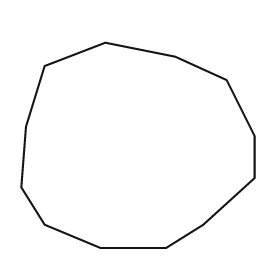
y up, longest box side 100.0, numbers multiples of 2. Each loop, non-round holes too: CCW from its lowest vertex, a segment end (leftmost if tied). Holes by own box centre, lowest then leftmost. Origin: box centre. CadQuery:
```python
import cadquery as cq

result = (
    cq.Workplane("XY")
    .moveTo(-16.0, -44.0)
    .lineTo(12.0, -44.0)
    .lineTo(28.0, -34.0)
    .lineTo(50.0, -14.0)
    .lineTo(50.0, 4.0)
    .lineTo(38.0, 28.0)
    .lineTo(16.0, 38.0)
    .lineTo(-14.0, 44.0)
    .lineTo(-40.0, 34.0)
    .lineTo(-48.0, 8.0)
    .lineTo(-50.0, -18.0)
    .lineTo(-40.0, -34.0)
    .close()
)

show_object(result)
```